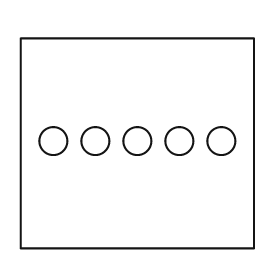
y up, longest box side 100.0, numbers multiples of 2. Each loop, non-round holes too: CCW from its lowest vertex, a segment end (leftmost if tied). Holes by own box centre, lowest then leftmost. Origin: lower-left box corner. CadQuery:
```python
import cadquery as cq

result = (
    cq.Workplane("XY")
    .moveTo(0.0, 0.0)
    .lineTo(100.0, 0.0)
    .lineTo(100.0, 90.0)
    .lineTo(0.0, 90.0)
    .close()
    .moveTo(14.0, 46.0)
    .circle(6.0)
    .moveTo(32.0, 46.0)
    .circle(6.0)
    .moveTo(50.0, 46.0)
    .circle(6.0)
    .moveTo(68.0, 46.0)
    .circle(6.0)
    .moveTo(86.0, 46.0)
    .circle(6.0)
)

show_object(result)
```